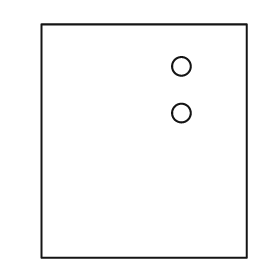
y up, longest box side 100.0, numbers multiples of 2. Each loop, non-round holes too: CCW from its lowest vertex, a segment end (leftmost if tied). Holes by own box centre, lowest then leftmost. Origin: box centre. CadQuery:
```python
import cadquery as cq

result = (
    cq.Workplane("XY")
    .moveTo(-44.0, -50.0)
    .lineTo(44.0, -50.0)
    .lineTo(44.0, 50.0)
    .lineTo(-44.0, 50.0)
    .close()
    .moveTo(16.0, 12.0)
    .circle(4.0)
    .moveTo(16.0, 32.0)
    .circle(4.0)
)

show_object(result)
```